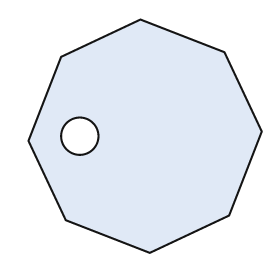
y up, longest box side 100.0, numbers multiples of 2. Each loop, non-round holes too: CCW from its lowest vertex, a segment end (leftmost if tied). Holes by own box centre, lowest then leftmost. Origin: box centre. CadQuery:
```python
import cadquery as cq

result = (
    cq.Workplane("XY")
    .moveTo(2.0, -50.0)
    .lineTo(36.0, -34.0)
    .lineTo(50.0, 2.0)
    .lineTo(34.0, 36.0)
    .lineTo(-2.0, 50.0)
    .lineTo(-36.0, 34.0)
    .lineTo(-50.0, -2.0)
    .lineTo(-34.0, -36.0)
    .close()
    .moveTo(-28.0, 0.0)
    .circle(8.0)
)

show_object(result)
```